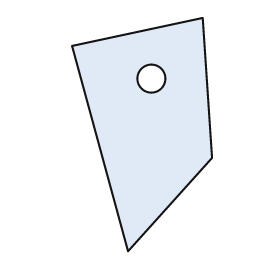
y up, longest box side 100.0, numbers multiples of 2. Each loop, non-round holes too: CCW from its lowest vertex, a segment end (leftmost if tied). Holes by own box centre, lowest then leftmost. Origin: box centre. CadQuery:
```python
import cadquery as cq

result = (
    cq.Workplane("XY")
    .moveTo(-6.0, -50.0)
    .lineTo(30.0, -10.0)
    .lineTo(26.0, 50.0)
    .lineTo(-30.0, 38.0)
    .close()
    .moveTo(4.0, 24.0)
    .circle(6.0)
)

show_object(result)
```